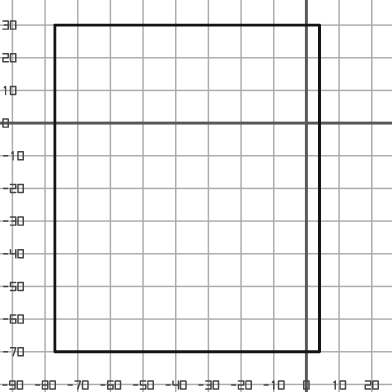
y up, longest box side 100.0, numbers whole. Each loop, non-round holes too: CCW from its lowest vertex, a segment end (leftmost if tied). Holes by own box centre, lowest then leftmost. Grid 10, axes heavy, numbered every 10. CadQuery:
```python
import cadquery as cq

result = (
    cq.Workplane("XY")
    .moveTo(-77.0, -70.0)
    .lineTo(4.0, -70.0)
    .lineTo(4.0, 30.0)
    .lineTo(-77.0, 30.0)
    .close()
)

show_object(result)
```